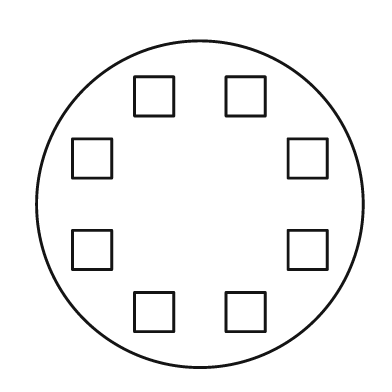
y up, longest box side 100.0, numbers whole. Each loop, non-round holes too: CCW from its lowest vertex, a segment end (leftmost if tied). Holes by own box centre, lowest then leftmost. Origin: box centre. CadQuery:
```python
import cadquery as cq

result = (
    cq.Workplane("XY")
    .moveTo(0.0, 0.0)
    .circle(50.0)
    .moveTo(-20.0, -39.0)
    .lineTo(-8.0, -39.0)
    .lineTo(-8.0, -27.0)
    .lineTo(-20.0, -27.0)
    .close()
    .moveTo(8.0, -39.0)
    .lineTo(20.0, -39.0)
    .lineTo(20.0, -27.0)
    .lineTo(8.0, -27.0)
    .close()
    .moveTo(-39.0, -20.0)
    .lineTo(-27.0, -20.0)
    .lineTo(-27.0, -8.0)
    .lineTo(-39.0, -8.0)
    .close()
    .moveTo(27.0, -20.0)
    .lineTo(39.0, -20.0)
    .lineTo(39.0, -8.0)
    .lineTo(27.0, -8.0)
    .close()
    .moveTo(-39.0, 8.0)
    .lineTo(-27.0, 8.0)
    .lineTo(-27.0, 20.0)
    .lineTo(-39.0, 20.0)
    .close()
    .moveTo(27.0, 8.0)
    .lineTo(39.0, 8.0)
    .lineTo(39.0, 20.0)
    .lineTo(27.0, 20.0)
    .close()
    .moveTo(-20.0, 27.0)
    .lineTo(-8.0, 27.0)
    .lineTo(-8.0, 39.0)
    .lineTo(-20.0, 39.0)
    .close()
    .moveTo(8.0, 27.0)
    .lineTo(20.0, 27.0)
    .lineTo(20.0, 39.0)
    .lineTo(8.0, 39.0)
    .close()
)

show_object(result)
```